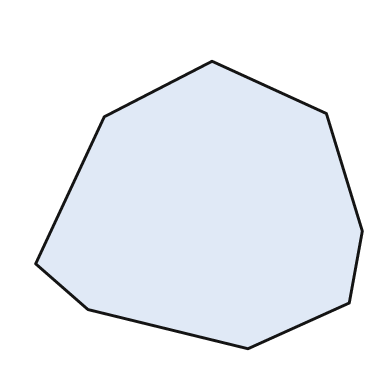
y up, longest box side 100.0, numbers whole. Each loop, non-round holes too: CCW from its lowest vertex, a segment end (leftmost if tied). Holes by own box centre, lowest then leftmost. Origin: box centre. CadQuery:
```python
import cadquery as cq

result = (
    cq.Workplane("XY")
    .moveTo(15.0, -44.0)
    .lineTo(46.0, -30.0)
    .lineTo(50.0, -8.0)
    .lineTo(39.0, 28.0)
    .lineTo(4.0, 44.0)
    .lineTo(-29.0, 27.0)
    .lineTo(-50.0, -18.0)
    .lineTo(-34.0, -32.0)
    .close()
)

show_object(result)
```